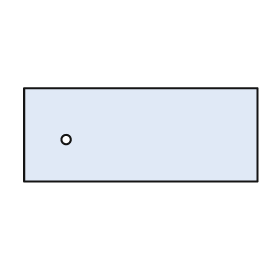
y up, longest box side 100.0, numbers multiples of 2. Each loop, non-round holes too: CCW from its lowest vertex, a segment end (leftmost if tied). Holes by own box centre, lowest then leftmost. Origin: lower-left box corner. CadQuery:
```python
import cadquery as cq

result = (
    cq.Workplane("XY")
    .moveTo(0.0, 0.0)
    .lineTo(100.0, 0.0)
    .lineTo(100.0, 40.0)
    .lineTo(0.0, 40.0)
    .close()
    .moveTo(18.0, 18.0)
    .circle(2.0)
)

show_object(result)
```